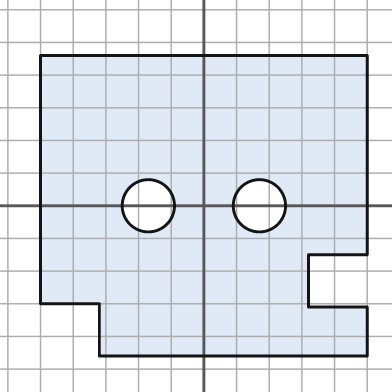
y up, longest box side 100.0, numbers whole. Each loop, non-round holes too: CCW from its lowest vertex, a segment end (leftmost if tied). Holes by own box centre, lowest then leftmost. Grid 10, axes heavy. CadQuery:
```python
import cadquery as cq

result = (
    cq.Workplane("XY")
    .moveTo(-32.0, -46.0)
    .lineTo(50.0, -46.0)
    .lineTo(50.0, -31.0)
    .lineTo(32.0, -31.0)
    .lineTo(32.0, -15.0)
    .lineTo(50.0, -15.0)
    .lineTo(50.0, 46.0)
    .lineTo(-50.0, 46.0)
    .lineTo(-50.0, -30.0)
    .lineTo(-32.0, -30.0)
    .close()
    .moveTo(-17.0, 0.0)
    .circle(8.0)
    .moveTo(17.0, 0.0)
    .circle(8.0)
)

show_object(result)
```